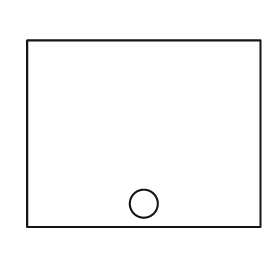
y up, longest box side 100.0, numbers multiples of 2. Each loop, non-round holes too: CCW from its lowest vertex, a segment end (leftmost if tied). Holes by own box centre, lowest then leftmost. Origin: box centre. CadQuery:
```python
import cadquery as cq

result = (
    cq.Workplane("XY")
    .moveTo(-50.0, -40.0)
    .lineTo(50.0, -40.0)
    .lineTo(50.0, 40.0)
    .lineTo(-50.0, 40.0)
    .close()
    .moveTo(0.0, -30.0)
    .circle(6.0)
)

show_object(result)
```